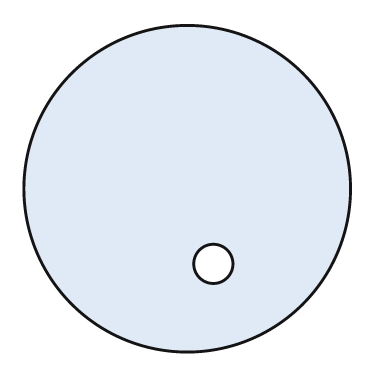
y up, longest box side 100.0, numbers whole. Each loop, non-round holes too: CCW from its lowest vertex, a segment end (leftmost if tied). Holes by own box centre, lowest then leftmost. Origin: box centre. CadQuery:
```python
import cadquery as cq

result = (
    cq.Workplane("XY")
    .moveTo(0.0, 0.0)
    .circle(50.0)
    .moveTo(8.0, -23.0)
    .circle(6.0)
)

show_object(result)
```